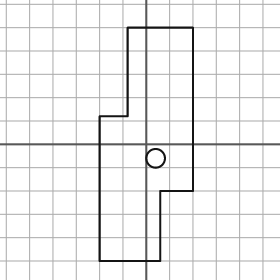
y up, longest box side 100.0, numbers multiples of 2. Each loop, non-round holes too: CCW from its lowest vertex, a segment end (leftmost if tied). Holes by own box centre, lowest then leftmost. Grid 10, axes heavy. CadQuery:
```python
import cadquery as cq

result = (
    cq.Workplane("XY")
    .moveTo(-20.0, -50.0)
    .lineTo(6.0, -50.0)
    .lineTo(6.0, -20.0)
    .lineTo(20.0, -20.0)
    .lineTo(20.0, 50.0)
    .lineTo(-8.0, 50.0)
    .lineTo(-8.0, 12.0)
    .lineTo(-20.0, 12.0)
    .close()
    .moveTo(4.0, -6.0)
    .circle(4.0)
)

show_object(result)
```